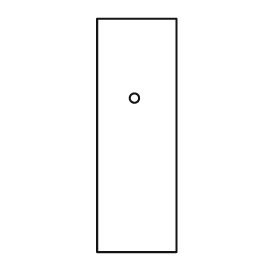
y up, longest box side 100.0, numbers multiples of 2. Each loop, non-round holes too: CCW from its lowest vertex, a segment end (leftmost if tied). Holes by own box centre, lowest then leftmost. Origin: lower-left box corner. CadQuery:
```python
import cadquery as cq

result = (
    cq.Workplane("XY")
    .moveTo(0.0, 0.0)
    .lineTo(34.0, 0.0)
    .lineTo(34.0, 100.0)
    .lineTo(0.0, 100.0)
    .close()
    .moveTo(16.0, 66.0)
    .circle(2.0)
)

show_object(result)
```